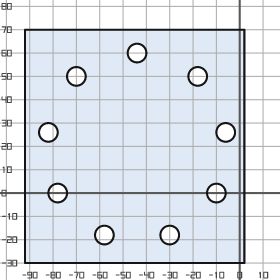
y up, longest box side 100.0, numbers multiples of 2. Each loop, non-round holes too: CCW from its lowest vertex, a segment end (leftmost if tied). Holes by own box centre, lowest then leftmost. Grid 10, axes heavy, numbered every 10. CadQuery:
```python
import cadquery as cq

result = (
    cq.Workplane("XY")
    .moveTo(-92.0, -30.0)
    .lineTo(2.0, -30.0)
    .lineTo(2.0, 70.0)
    .lineTo(-92.0, 70.0)
    .close()
    .moveTo(-58.0, -18.0)
    .circle(4.0)
    .moveTo(-30.0, -18.0)
    .circle(4.0)
    .moveTo(-78.0, 0.0)
    .circle(4.0)
    .moveTo(-10.0, 0.0)
    .circle(4.0)
    .moveTo(-82.0, 26.0)
    .circle(4.0)
    .moveTo(-6.0, 26.0)
    .circle(4.0)
    .moveTo(-70.0, 50.0)
    .circle(4.0)
    .moveTo(-18.0, 50.0)
    .circle(4.0)
    .moveTo(-44.0, 60.0)
    .circle(4.0)
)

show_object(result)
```